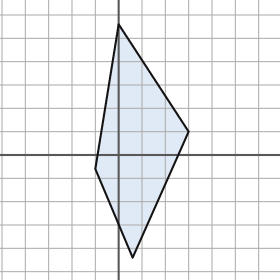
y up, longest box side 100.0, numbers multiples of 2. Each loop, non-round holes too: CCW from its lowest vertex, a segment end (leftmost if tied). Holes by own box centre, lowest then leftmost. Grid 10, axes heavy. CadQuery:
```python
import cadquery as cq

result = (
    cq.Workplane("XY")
    .moveTo(6.0, -44.0)
    .lineTo(30.0, 10.0)
    .lineTo(0.0, 56.0)
    .lineTo(-10.0, -6.0)
    .close()
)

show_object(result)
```